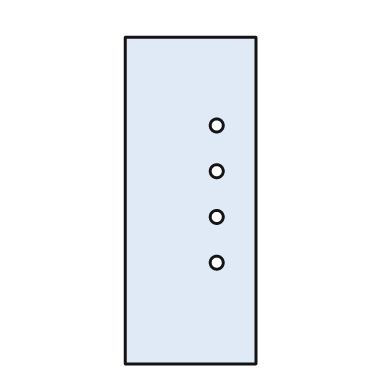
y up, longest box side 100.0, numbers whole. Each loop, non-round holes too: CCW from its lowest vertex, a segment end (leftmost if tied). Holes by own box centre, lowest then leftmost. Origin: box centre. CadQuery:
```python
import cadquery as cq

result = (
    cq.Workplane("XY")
    .moveTo(-20.0, -50.0)
    .lineTo(20.0, -50.0)
    .lineTo(20.0, 50.0)
    .lineTo(-20.0, 50.0)
    .close()
    .moveTo(8.0, -19.0)
    .circle(2.0)
    .moveTo(8.0, -5.0)
    .circle(2.0)
    .moveTo(8.0, 9.0)
    .circle(2.0)
    .moveTo(8.0, 23.0)
    .circle(2.0)
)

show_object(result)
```